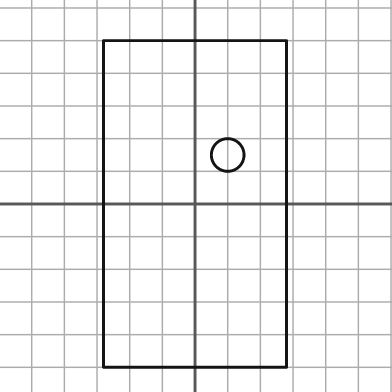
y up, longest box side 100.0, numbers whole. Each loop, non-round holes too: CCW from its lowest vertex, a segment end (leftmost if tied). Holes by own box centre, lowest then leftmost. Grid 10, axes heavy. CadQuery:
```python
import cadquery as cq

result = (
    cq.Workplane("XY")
    .moveTo(-28.0, -50.0)
    .lineTo(28.0, -50.0)
    .lineTo(28.0, 50.0)
    .lineTo(-28.0, 50.0)
    .close()
    .moveTo(10.0, 15.0)
    .circle(5.0)
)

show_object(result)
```